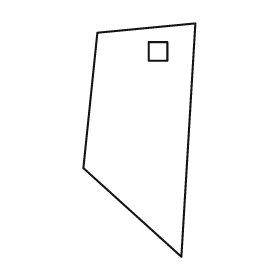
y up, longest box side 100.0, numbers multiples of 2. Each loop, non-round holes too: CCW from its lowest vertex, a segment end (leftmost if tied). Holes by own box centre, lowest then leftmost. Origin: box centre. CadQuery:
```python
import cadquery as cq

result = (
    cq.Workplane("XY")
    .moveTo(18.0, -50.0)
    .lineTo(24.0, 50.0)
    .lineTo(-18.0, 46.0)
    .lineTo(-24.0, -12.0)
    .close()
    .moveTo(4.0, 34.0)
    .lineTo(12.0, 34.0)
    .lineTo(12.0, 42.0)
    .lineTo(4.0, 42.0)
    .close()
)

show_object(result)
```